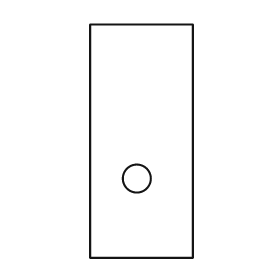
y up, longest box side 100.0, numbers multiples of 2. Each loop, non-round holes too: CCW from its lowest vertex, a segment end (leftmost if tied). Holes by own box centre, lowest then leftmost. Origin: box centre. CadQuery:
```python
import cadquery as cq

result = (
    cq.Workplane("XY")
    .moveTo(-22.0, -50.0)
    .lineTo(22.0, -50.0)
    .lineTo(22.0, 50.0)
    .lineTo(-22.0, 50.0)
    .close()
    .moveTo(-2.0, -16.0)
    .circle(6.0)
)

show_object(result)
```